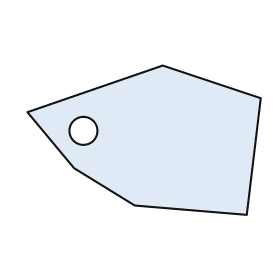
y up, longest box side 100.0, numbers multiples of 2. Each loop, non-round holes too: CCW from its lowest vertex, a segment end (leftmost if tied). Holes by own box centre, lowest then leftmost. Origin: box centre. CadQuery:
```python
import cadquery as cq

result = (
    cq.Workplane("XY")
    .moveTo(44.0, -32.0)
    .lineTo(50.0, 18.0)
    .lineTo(8.0, 32.0)
    .lineTo(-50.0, 12.0)
    .lineTo(-30.0, -12.0)
    .lineTo(-4.0, -28.0)
    .close()
    .moveTo(-26.0, 4.0)
    .circle(6.0)
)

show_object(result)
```